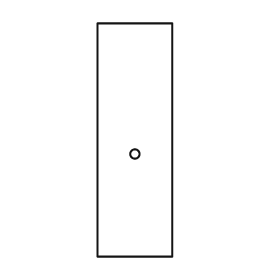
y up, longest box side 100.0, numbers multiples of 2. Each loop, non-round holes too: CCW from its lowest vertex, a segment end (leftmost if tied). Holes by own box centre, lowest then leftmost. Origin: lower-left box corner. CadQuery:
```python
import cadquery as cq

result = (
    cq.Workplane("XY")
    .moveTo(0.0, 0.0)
    .lineTo(32.0, 0.0)
    .lineTo(32.0, 100.0)
    .lineTo(0.0, 100.0)
    .close()
    .moveTo(16.0, 44.0)
    .circle(2.0)
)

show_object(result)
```